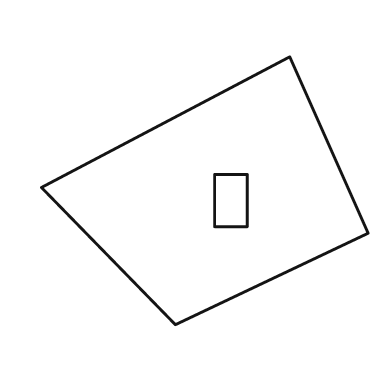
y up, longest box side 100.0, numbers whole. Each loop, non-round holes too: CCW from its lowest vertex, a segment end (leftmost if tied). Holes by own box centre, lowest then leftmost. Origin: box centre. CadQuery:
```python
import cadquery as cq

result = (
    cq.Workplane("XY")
    .moveTo(-9.0, -41.0)
    .lineTo(50.0, -13.0)
    .lineTo(26.0, 41.0)
    .lineTo(-50.0, 1.0)
    .close()
    .moveTo(3.0, -11.0)
    .lineTo(13.0, -11.0)
    .lineTo(13.0, 5.0)
    .lineTo(3.0, 5.0)
    .close()
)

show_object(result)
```